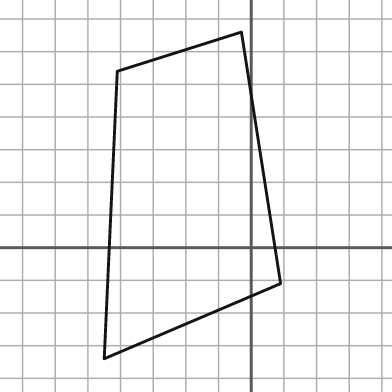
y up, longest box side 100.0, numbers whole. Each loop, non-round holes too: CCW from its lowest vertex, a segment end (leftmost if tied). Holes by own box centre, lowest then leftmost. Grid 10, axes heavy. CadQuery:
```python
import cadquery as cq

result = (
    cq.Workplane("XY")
    .moveTo(-45.0, -34.0)
    .lineTo(9.0, -11.0)
    .lineTo(-3.0, 66.0)
    .lineTo(-41.0, 54.0)
    .close()
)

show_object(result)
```